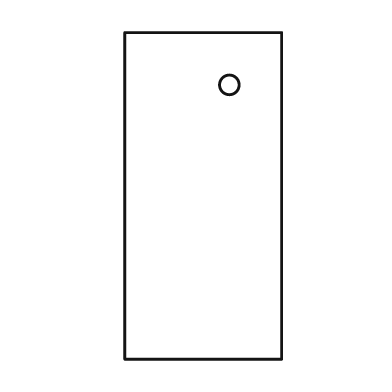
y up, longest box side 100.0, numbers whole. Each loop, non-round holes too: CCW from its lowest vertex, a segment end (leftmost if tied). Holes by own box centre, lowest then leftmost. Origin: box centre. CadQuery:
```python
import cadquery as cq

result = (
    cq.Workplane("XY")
    .moveTo(-24.0, -50.0)
    .lineTo(24.0, -50.0)
    .lineTo(24.0, 50.0)
    .lineTo(-24.0, 50.0)
    .close()
    .moveTo(8.0, 34.0)
    .circle(3.0)
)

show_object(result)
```